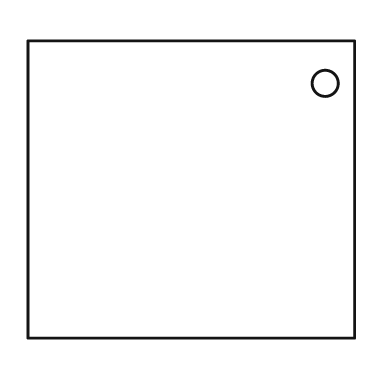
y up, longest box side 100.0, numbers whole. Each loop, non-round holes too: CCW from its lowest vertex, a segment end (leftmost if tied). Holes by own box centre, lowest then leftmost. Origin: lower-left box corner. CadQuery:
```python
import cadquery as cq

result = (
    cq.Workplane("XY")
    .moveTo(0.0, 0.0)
    .lineTo(100.0, 0.0)
    .lineTo(100.0, 91.0)
    .lineTo(0.0, 91.0)
    .close()
    .moveTo(91.0, 78.0)
    .circle(4.0)
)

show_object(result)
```